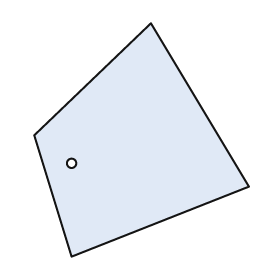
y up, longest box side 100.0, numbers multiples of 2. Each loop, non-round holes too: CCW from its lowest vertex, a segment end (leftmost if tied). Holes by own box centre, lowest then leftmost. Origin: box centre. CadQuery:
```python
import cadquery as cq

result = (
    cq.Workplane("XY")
    .moveTo(-30.0, -50.0)
    .lineTo(46.0, -20.0)
    .lineTo(4.0, 50.0)
    .lineTo(-46.0, 2.0)
    .close()
    .moveTo(-30.0, -10.0)
    .circle(2.0)
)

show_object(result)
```